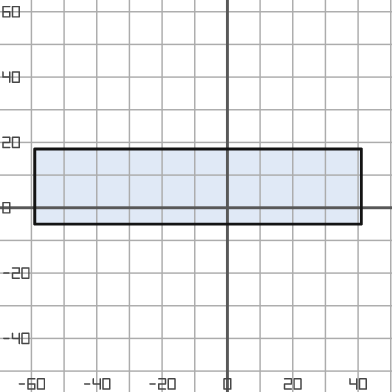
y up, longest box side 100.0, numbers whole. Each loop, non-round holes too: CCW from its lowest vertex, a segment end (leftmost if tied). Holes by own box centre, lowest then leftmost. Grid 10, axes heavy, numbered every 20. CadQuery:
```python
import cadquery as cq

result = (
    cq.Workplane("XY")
    .moveTo(-59.0, -5.0)
    .lineTo(41.0, -5.0)
    .lineTo(41.0, 18.0)
    .lineTo(-59.0, 18.0)
    .close()
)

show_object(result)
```